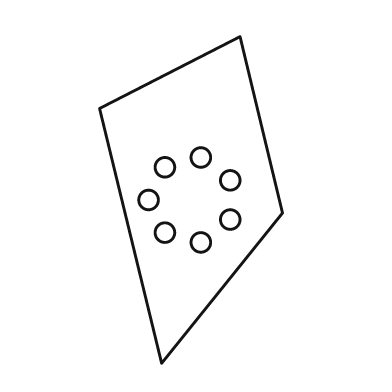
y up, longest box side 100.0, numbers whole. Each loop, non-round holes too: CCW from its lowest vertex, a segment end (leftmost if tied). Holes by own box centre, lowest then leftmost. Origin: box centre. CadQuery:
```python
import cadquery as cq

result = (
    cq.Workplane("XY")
    .moveTo(-9.0, -50.0)
    .lineTo(28.0, -4.0)
    .lineTo(15.0, 50.0)
    .lineTo(-28.0, 28.0)
    .close()
    .moveTo(3.0, -13.0)
    .circle(3.0)
    .moveTo(-8.0, -10.0)
    .circle(3.0)
    .moveTo(12.0, -6.0)
    .circle(3.0)
    .moveTo(-13.0, 0.0)
    .circle(3.0)
    .moveTo(12.0, 6.0)
    .circle(3.0)
    .moveTo(-8.0, 10.0)
    .circle(3.0)
    .moveTo(3.0, 13.0)
    .circle(3.0)
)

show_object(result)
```